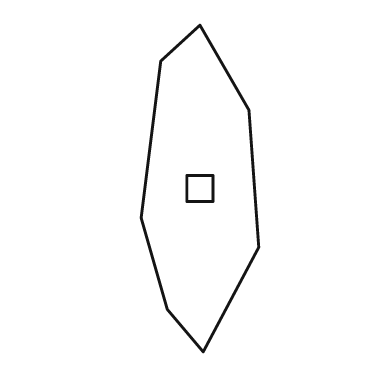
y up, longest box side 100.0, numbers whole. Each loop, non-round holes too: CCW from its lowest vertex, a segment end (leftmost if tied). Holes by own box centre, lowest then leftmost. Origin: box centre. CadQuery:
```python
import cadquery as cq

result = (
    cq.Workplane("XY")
    .moveTo(1.0, -50.0)
    .lineTo(18.0, -18.0)
    .lineTo(15.0, 24.0)
    .lineTo(0.0, 50.0)
    .lineTo(-12.0, 39.0)
    .lineTo(-18.0, -9.0)
    .lineTo(-10.0, -37.0)
    .close()
    .moveTo(-4.0, -4.0)
    .lineTo(4.0, -4.0)
    .lineTo(4.0, 4.0)
    .lineTo(-4.0, 4.0)
    .close()
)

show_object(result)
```